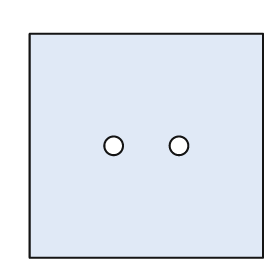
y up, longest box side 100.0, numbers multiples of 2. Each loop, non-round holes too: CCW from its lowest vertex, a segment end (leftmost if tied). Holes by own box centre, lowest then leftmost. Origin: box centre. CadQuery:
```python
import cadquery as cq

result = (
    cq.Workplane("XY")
    .moveTo(-50.0, -48.0)
    .lineTo(50.0, -48.0)
    .lineTo(50.0, 48.0)
    .lineTo(-50.0, 48.0)
    .close()
    .moveTo(-14.0, 0.0)
    .circle(4.0)
    .moveTo(14.0, 0.0)
    .circle(4.0)
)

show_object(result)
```